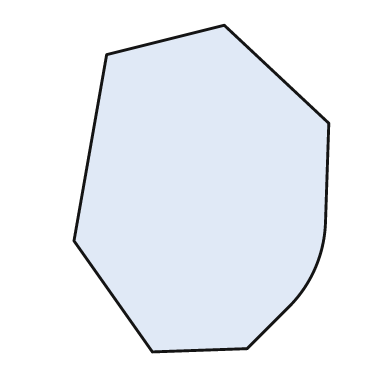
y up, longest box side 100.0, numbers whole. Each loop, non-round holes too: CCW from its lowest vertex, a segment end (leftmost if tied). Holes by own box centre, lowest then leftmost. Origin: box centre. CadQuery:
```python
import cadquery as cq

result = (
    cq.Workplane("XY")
    .moveTo(-15.0, -50.0)
    .lineTo(14.0, -49.0)
    .lineTo(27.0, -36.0)
    .threePointArc((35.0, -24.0), (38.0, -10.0))
    .lineTo(39.0, 20.0)
    .lineTo(7.0, 50.0)
    .lineTo(-29.0, 41.0)
    .lineTo(-39.0, -16.0)
    .close()
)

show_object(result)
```